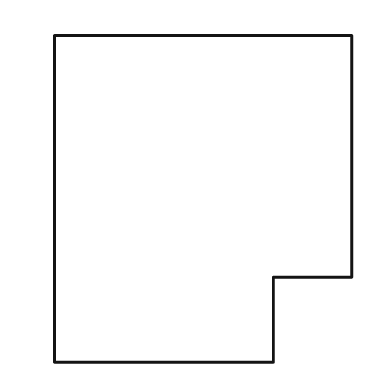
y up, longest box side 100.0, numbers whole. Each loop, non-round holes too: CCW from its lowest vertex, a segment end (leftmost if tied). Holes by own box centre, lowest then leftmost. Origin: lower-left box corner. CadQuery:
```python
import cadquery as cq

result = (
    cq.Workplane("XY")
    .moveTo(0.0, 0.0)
    .lineTo(67.0, 0.0)
    .lineTo(67.0, 26.0)
    .lineTo(91.0, 26.0)
    .lineTo(91.0, 100.0)
    .lineTo(0.0, 100.0)
    .close()
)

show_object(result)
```